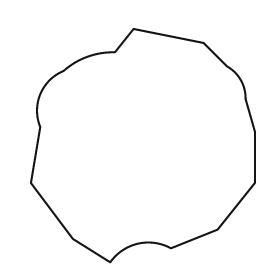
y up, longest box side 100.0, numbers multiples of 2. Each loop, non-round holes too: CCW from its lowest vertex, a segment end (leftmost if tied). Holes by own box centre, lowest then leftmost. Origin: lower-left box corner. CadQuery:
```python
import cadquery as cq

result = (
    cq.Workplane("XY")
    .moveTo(34.0, 0.0)
    .threePointArc((46.0, 8.0), (60.0, 6.0))
    .lineTo(80.0, 14.0)
    .lineTo(96.0, 34.0)
    .lineTo(96.0, 56.0)
    .lineTo(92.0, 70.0)
    .threePointArc((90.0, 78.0), (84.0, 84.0))
    .lineTo(74.0, 94.0)
    .lineTo(44.0, 100.0)
    .lineTo(36.0, 90.0)
    .threePointArc((24.0, 88.0), (14.0, 82.0))
    .threePointArc((4.0, 72.0), (4.0, 58.0))
    .lineTo(0.0, 34.0)
    .lineTo(18.0, 10.0)
    .close()
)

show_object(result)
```